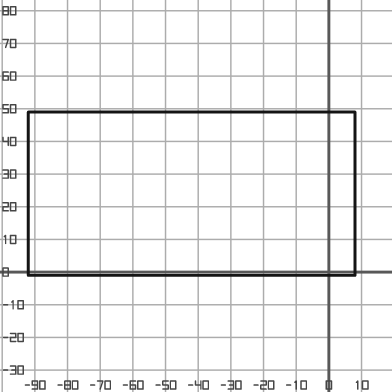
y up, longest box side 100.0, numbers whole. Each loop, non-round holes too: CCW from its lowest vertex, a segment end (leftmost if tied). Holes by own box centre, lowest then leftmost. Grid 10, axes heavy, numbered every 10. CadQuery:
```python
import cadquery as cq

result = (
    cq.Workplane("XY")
    .moveTo(-92.0, -1.0)
    .lineTo(8.0, -1.0)
    .lineTo(8.0, 49.0)
    .lineTo(-92.0, 49.0)
    .close()
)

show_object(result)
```